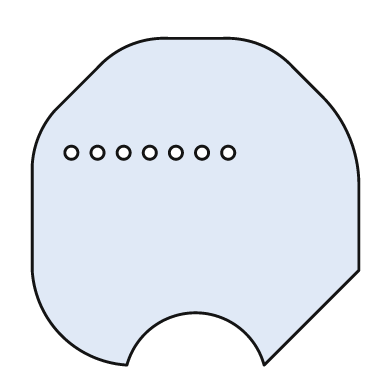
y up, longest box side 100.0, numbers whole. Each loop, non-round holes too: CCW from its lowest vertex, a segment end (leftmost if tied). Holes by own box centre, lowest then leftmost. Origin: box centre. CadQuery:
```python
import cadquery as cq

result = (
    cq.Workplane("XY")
    .moveTo(-21.0, -50.0)
    .threePointArc((0.0, -34.0), (21.0, -50.0))
    .lineTo(50.0, -21.0)
    .lineTo(50.0, 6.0)
    .threePointArc((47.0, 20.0), (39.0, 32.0))
    .lineTo(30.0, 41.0)
    .threePointArc((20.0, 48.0), (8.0, 50.0))
    .lineTo(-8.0, 50.0)
    .threePointArc((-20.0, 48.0), (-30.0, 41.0))
    .lineTo(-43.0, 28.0)
    .threePointArc((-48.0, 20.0), (-50.0, 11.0))
    .lineTo(-50.0, -21.0)
    .threePointArc((-41.0, -41.0), (-21.0, -50.0))
    .close()
    .moveTo(-38.0, 15.0)
    .circle(2.0)
    .moveTo(-30.0, 15.0)
    .circle(2.0)
    .moveTo(-22.0, 15.0)
    .circle(2.0)
    .moveTo(-14.0, 15.0)
    .circle(2.0)
    .moveTo(-6.0, 15.0)
    .circle(2.0)
    .moveTo(2.0, 15.0)
    .circle(2.0)
    .moveTo(10.0, 15.0)
    .circle(2.0)
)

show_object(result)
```